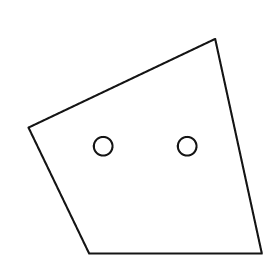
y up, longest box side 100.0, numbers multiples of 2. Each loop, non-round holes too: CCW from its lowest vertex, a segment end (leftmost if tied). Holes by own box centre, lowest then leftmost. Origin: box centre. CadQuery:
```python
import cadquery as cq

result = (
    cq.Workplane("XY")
    .moveTo(-24.0, -46.0)
    .lineTo(50.0, -46.0)
    .lineTo(30.0, 46.0)
    .lineTo(-50.0, 8.0)
    .close()
    .moveTo(-18.0, 0.0)
    .circle(4.0)
    .moveTo(18.0, 0.0)
    .circle(4.0)
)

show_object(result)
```